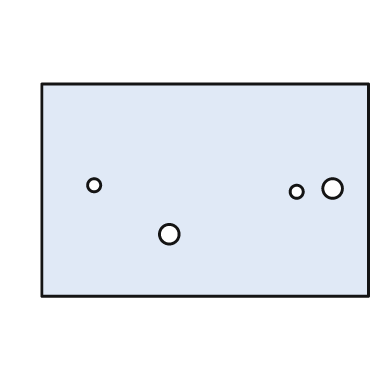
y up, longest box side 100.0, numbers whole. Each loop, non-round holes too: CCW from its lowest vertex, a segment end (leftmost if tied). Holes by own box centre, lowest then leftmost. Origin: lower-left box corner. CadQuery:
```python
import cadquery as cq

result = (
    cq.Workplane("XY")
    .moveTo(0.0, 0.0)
    .lineTo(100.0, 0.0)
    .lineTo(100.0, 65.0)
    .lineTo(0.0, 65.0)
    .close()
    .moveTo(39.0, 19.0)
    .circle(3.0)
    .moveTo(78.0, 32.0)
    .circle(2.0)
    .moveTo(89.0, 33.0)
    .circle(3.0)
    .moveTo(16.0, 34.0)
    .circle(2.0)
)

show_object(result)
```